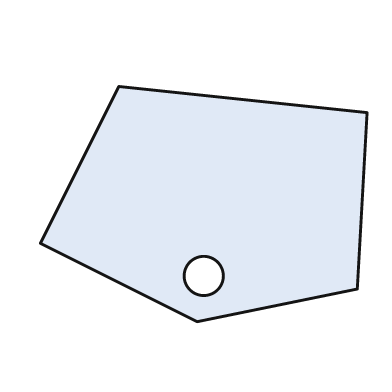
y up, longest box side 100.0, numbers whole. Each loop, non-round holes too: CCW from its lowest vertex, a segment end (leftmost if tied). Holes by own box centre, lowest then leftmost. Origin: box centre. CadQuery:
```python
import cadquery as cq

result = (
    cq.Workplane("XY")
    .moveTo(-2.0, -36.0)
    .lineTo(47.0, -26.0)
    .lineTo(50.0, 28.0)
    .lineTo(-26.0, 36.0)
    .lineTo(-50.0, -12.0)
    .close()
    .moveTo(0.0, -22.0)
    .circle(6.0)
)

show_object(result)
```